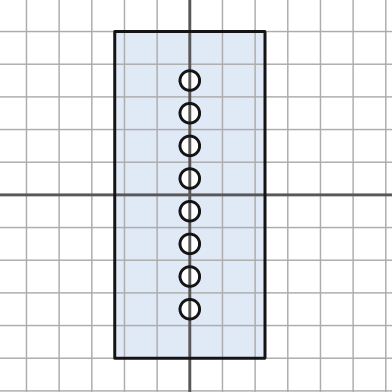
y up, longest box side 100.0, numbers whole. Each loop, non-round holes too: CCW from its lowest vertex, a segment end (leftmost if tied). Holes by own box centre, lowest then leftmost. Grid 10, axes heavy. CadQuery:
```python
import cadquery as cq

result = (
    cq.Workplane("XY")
    .moveTo(-23.0, -50.0)
    .lineTo(23.0, -50.0)
    .lineTo(23.0, 50.0)
    .lineTo(-23.0, 50.0)
    .close()
    .moveTo(0.0, -35.0)
    .circle(3.0)
    .moveTo(0.0, -25.0)
    .circle(3.0)
    .moveTo(0.0, -15.0)
    .circle(3.0)
    .moveTo(0.0, -5.0)
    .circle(3.0)
    .moveTo(0.0, 5.0)
    .circle(3.0)
    .moveTo(0.0, 15.0)
    .circle(3.0)
    .moveTo(0.0, 25.0)
    .circle(3.0)
    .moveTo(0.0, 35.0)
    .circle(3.0)
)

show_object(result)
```